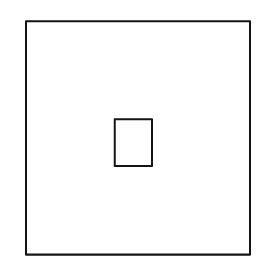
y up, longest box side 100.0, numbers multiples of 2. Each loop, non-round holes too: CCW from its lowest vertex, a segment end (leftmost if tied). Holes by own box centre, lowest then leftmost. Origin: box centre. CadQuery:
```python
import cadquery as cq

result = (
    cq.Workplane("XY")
    .moveTo(-48.0, -50.0)
    .lineTo(48.0, -50.0)
    .lineTo(48.0, 50.0)
    .lineTo(-48.0, 50.0)
    .close()
    .moveTo(-10.0, -12.0)
    .lineTo(6.0, -12.0)
    .lineTo(6.0, 8.0)
    .lineTo(-10.0, 8.0)
    .close()
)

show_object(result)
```